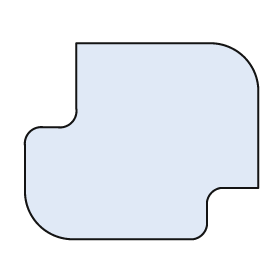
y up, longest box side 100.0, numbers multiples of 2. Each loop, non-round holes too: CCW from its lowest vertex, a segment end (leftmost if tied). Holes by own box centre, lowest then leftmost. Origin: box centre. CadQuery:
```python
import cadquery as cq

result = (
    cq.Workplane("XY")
    .moveTo(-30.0, -42.0)
    .lineTo(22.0, -42.0)
    .threePointArc((26.0, -40.0), (28.0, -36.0))
    .lineTo(28.0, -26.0)
    .threePointArc((30.0, -22.0), (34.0, -20.0))
    .lineTo(50.0, -20.0)
    .lineTo(50.0, 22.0)
    .threePointArc((44.0, 36.0), (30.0, 42.0))
    .lineTo(-28.0, 42.0)
    .lineTo(-28.0, 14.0)
    .threePointArc((-30.0, 8.0), (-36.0, 6.0))
    .lineTo(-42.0, 6.0)
    .threePointArc((-48.0, 4.0), (-50.0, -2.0))
    .lineTo(-50.0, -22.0)
    .threePointArc((-44.0, -36.0), (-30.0, -42.0))
    .close()
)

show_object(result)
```